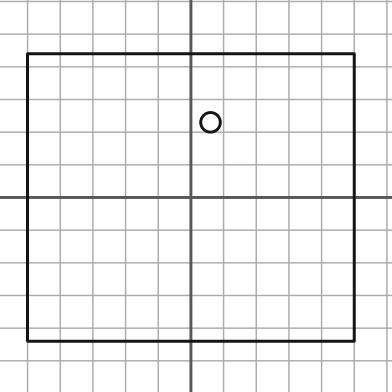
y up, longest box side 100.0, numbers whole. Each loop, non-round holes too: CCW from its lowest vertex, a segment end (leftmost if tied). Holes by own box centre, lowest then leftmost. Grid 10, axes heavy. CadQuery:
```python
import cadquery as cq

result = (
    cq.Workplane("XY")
    .moveTo(-50.0, -44.0)
    .lineTo(50.0, -44.0)
    .lineTo(50.0, 44.0)
    .lineTo(-50.0, 44.0)
    .close()
    .moveTo(6.0, 23.0)
    .circle(3.0)
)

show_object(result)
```